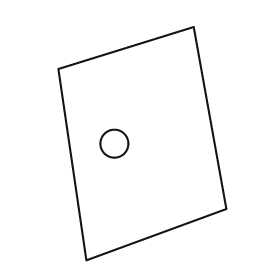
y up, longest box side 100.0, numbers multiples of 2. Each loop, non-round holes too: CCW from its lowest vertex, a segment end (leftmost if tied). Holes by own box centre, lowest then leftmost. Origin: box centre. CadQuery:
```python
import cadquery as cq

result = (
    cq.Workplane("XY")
    .moveTo(-24.0, -50.0)
    .lineTo(36.0, -28.0)
    .lineTo(22.0, 50.0)
    .lineTo(-36.0, 32.0)
    .close()
    .moveTo(-12.0, 0.0)
    .circle(6.0)
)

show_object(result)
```